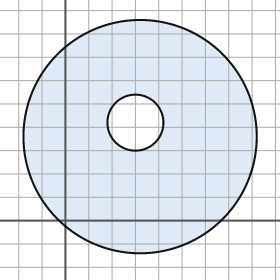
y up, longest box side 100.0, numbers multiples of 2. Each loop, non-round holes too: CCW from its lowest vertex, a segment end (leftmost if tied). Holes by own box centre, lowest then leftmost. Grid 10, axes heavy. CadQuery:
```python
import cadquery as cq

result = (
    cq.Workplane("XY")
    .moveTo(32.0, 36.0)
    .circle(50.0)
    .moveTo(30.0, 42.0)
    .circle(12.0)
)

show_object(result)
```